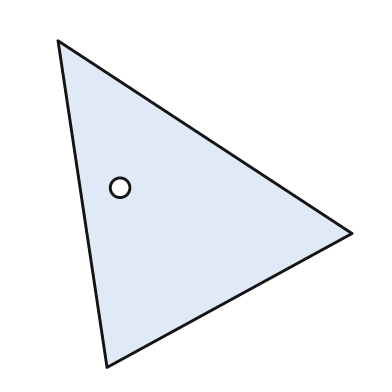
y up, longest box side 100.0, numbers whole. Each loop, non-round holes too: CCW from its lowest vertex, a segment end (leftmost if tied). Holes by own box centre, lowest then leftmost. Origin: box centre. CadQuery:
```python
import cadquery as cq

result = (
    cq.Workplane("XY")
    .moveTo(-30.0, -50.0)
    .lineTo(45.0, -9.0)
    .lineTo(-45.0, 50.0)
    .close()
    .moveTo(-26.0, 5.0)
    .circle(3.0)
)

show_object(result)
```